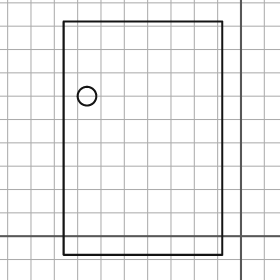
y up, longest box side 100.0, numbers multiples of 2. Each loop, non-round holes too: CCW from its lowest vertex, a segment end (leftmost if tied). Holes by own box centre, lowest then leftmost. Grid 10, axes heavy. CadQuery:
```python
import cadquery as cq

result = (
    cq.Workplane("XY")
    .moveTo(-76.0, -8.0)
    .lineTo(-8.0, -8.0)
    .lineTo(-8.0, 92.0)
    .lineTo(-76.0, 92.0)
    .close()
    .moveTo(-66.0, 60.0)
    .circle(4.0)
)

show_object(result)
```